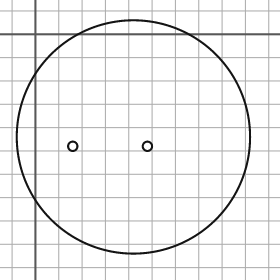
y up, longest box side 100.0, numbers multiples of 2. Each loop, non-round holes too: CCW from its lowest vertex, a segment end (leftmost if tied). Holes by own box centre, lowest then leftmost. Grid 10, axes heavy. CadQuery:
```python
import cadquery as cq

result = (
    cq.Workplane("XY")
    .moveTo(42.0, -44.0)
    .circle(50.0)
    .moveTo(16.0, -48.0)
    .circle(2.0)
    .moveTo(48.0, -48.0)
    .circle(2.0)
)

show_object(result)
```